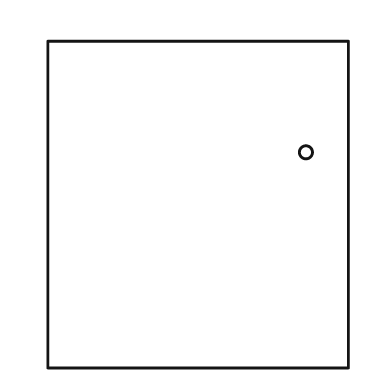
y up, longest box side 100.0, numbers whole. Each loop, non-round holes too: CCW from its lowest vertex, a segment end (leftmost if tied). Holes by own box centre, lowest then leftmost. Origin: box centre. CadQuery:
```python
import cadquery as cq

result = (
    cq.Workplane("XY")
    .moveTo(-46.0, -50.0)
    .lineTo(46.0, -50.0)
    .lineTo(46.0, 50.0)
    .lineTo(-46.0, 50.0)
    .close()
    .moveTo(33.0, 16.0)
    .circle(2.0)
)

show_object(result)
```